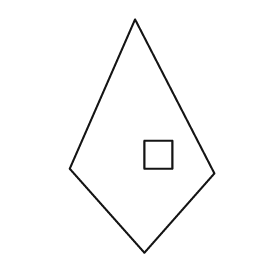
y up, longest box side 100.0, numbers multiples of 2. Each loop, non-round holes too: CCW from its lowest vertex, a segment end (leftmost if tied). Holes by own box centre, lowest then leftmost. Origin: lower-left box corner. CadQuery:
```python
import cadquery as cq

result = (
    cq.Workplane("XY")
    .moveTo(32.0, 0.0)
    .lineTo(62.0, 34.0)
    .lineTo(28.0, 100.0)
    .lineTo(0.0, 36.0)
    .close()
    .moveTo(32.0, 36.0)
    .lineTo(44.0, 36.0)
    .lineTo(44.0, 48.0)
    .lineTo(32.0, 48.0)
    .close()
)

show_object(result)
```